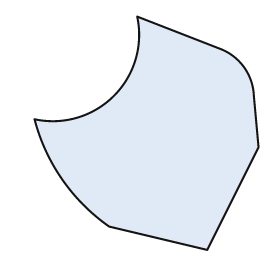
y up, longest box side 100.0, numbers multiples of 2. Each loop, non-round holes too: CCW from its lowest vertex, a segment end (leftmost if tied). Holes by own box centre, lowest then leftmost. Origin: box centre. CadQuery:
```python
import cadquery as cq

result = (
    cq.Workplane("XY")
    .moveTo(26.0, -50.0)
    .lineTo(48.0, -6.0)
    .lineTo(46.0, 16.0)
    .threePointArc((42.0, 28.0), (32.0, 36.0))
    .lineTo(-4.0, 50.0)
    .threePointArc((-14.0, 16.0), (-48.0, 6.0))
    .threePointArc((-36.0, -20.0), (-16.0, -40.0))
    .close()
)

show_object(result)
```